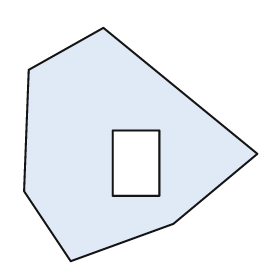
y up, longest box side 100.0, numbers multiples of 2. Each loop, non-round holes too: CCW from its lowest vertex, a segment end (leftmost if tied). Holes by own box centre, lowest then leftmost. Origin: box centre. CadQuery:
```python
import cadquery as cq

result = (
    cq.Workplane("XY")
    .moveTo(-30.0, -50.0)
    .lineTo(14.0, -34.0)
    .lineTo(50.0, -4.0)
    .lineTo(-16.0, 50.0)
    .lineTo(-48.0, 32.0)
    .lineTo(-50.0, -20.0)
    .close()
    .moveTo(-12.0, -22.0)
    .lineTo(8.0, -22.0)
    .lineTo(8.0, 6.0)
    .lineTo(-12.0, 6.0)
    .close()
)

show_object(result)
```